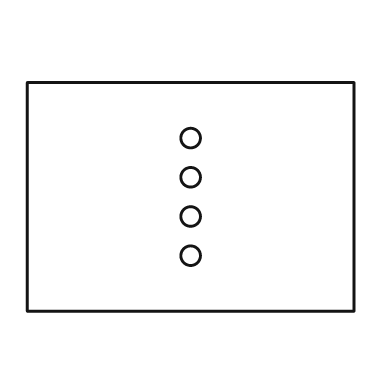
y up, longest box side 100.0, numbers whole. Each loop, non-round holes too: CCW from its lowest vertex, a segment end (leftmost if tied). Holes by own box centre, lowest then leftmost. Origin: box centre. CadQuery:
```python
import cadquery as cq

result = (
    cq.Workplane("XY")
    .moveTo(-50.0, -35.0)
    .lineTo(50.0, -35.0)
    .lineTo(50.0, 35.0)
    .lineTo(-50.0, 35.0)
    .close()
    .moveTo(0.0, -18.0)
    .circle(3.0)
    .moveTo(0.0, -6.0)
    .circle(3.0)
    .moveTo(0.0, 6.0)
    .circle(3.0)
    .moveTo(0.0, 18.0)
    .circle(3.0)
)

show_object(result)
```